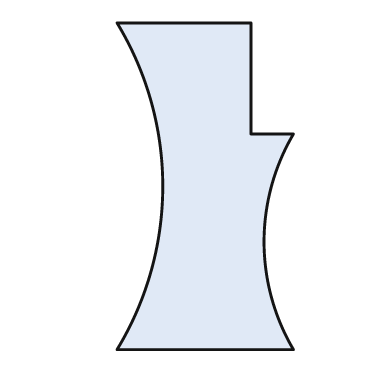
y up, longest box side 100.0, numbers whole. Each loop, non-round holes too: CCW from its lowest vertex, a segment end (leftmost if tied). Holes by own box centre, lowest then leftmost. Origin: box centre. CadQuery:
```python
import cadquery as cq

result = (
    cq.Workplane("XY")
    .moveTo(-27.0, -50.0)
    .lineTo(27.0, -50.0)
    .threePointArc((18.0, -17.0), (27.0, 16.0))
    .lineTo(14.0, 16.0)
    .lineTo(14.0, 50.0)
    .lineTo(-27.0, 50.0)
    .threePointArc((-13.0, 0.0), (-27.0, -50.0))
    .close()
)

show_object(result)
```